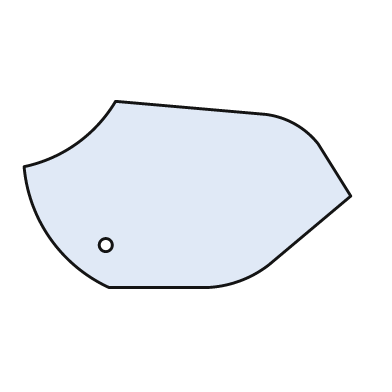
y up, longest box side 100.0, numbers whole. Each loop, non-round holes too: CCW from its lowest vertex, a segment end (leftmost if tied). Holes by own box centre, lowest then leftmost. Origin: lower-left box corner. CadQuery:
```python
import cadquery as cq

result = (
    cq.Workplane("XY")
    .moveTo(26.0, 0.0)
    .lineTo(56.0, 0.0)
    .threePointArc((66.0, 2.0), (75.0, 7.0))
    .lineTo(100.0, 28.0)
    .lineTo(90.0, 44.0)
    .threePointArc((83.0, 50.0), (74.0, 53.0))
    .lineTo(28.0, 57.0)
    .threePointArc((16.0, 44.0), (0.0, 37.0))
    .threePointArc((8.0, 15.0), (26.0, 0.0))
    .close()
    .moveTo(25.0, 13.0)
    .circle(2.0)
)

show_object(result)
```